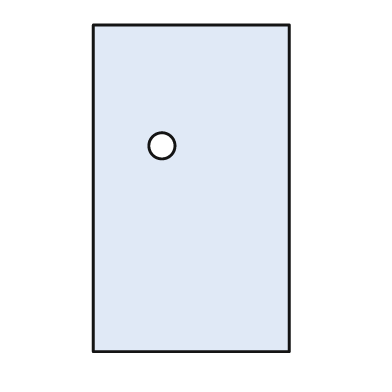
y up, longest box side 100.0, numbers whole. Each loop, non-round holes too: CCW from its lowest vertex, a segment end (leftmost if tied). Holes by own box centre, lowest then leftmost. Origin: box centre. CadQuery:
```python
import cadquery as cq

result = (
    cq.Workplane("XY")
    .moveTo(-30.0, -50.0)
    .lineTo(30.0, -50.0)
    .lineTo(30.0, 50.0)
    .lineTo(-30.0, 50.0)
    .close()
    .moveTo(-9.0, 13.0)
    .circle(4.0)
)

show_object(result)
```